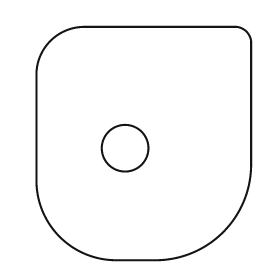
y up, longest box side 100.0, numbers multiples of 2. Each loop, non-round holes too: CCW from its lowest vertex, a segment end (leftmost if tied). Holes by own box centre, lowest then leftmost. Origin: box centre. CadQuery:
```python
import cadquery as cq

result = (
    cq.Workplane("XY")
    .moveTo(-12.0, -50.0)
    .lineTo(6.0, -50.0)
    .threePointArc((34.0, -38.0), (46.0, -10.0))
    .lineTo(46.0, 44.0)
    .threePointArc((44.0, 48.0), (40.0, 50.0))
    .lineTo(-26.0, 50.0)
    .threePointArc((-40.0, 44.0), (-46.0, 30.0))
    .lineTo(-46.0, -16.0)
    .threePointArc((-36.0, -40.0), (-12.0, -50.0))
    .close()
    .moveTo(-8.0, -2.0)
    .circle(10.0)
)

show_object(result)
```